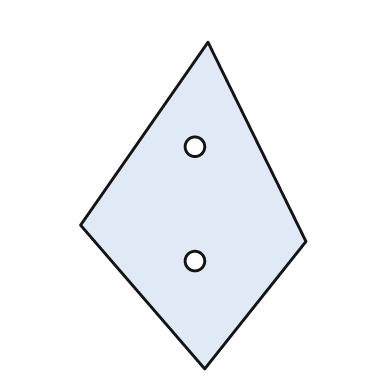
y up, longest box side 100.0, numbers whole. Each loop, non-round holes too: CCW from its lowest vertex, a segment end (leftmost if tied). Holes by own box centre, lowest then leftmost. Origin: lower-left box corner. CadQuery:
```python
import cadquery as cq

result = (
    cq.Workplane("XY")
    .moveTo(38.0, 0.0)
    .lineTo(69.0, 39.0)
    .lineTo(39.0, 100.0)
    .lineTo(0.0, 44.0)
    .close()
    .moveTo(35.0, 33.0)
    .circle(3.0)
    .moveTo(35.0, 68.0)
    .circle(3.0)
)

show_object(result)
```